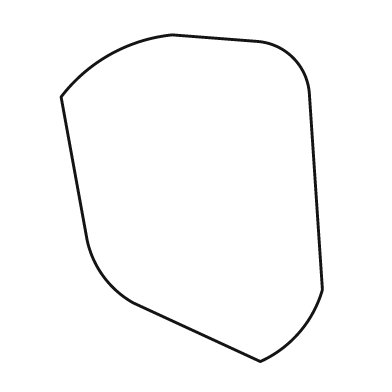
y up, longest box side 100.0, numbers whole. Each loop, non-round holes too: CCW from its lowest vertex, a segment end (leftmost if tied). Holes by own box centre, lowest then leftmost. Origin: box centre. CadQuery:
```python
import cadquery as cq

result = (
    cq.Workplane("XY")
    .moveTo(21.0, -50.0)
    .threePointArc((33.0, -41.0), (40.0, -28.0))
    .lineTo(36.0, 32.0)
    .threePointArc((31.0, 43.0), (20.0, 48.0))
    .lineTo(-6.0, 50.0)
    .threePointArc((-25.0, 44.0), (-40.0, 31.0))
    .lineTo(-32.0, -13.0)
    .threePointArc((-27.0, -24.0), (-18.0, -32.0))
    .close()
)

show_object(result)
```